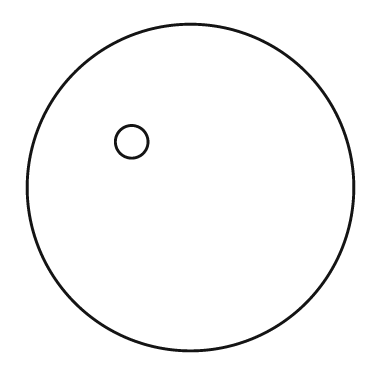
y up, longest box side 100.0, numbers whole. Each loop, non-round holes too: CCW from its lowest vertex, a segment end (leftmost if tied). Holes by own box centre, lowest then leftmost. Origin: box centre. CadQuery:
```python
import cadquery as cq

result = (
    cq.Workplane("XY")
    .moveTo(0.0, 0.0)
    .circle(50.0)
    .moveTo(-18.0, 14.0)
    .circle(5.0)
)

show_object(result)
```